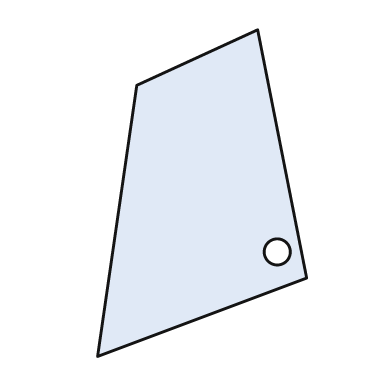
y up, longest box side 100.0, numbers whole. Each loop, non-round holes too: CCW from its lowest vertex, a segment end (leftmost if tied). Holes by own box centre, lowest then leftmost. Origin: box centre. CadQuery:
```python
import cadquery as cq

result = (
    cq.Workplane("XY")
    .moveTo(-32.0, -50.0)
    .lineTo(32.0, -26.0)
    .lineTo(17.0, 50.0)
    .lineTo(-20.0, 33.0)
    .close()
    .moveTo(23.0, -18.0)
    .circle(4.0)
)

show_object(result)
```